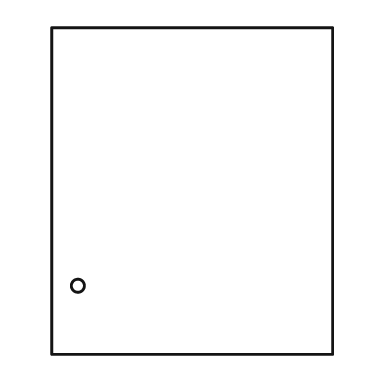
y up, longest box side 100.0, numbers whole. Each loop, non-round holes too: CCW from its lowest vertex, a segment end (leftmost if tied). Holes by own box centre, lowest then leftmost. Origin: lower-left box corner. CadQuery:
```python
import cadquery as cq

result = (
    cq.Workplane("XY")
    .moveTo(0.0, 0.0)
    .lineTo(86.0, 0.0)
    .lineTo(86.0, 100.0)
    .lineTo(0.0, 100.0)
    .close()
    .moveTo(8.0, 21.0)
    .circle(2.0)
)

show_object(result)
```